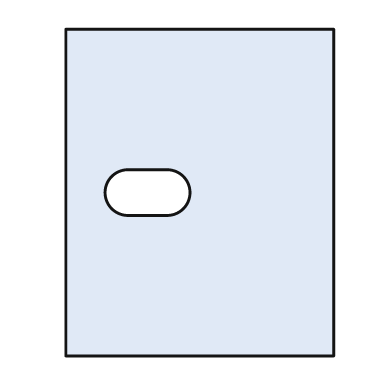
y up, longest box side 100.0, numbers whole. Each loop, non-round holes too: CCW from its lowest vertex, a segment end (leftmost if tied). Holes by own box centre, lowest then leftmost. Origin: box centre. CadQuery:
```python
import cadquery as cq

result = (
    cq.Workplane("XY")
    .moveTo(-41.0, -50.0)
    .lineTo(41.0, -50.0)
    .lineTo(41.0, 50.0)
    .lineTo(-41.0, 50.0)
    .close()
    .moveTo(-22.0, -7.0)
    .lineTo(-10.0, -7.0)
    .threePointArc((-3.0, 0.0), (-10.0, 7.0))
    .lineTo(-22.0, 7.0)
    .threePointArc((-29.0, 0.0), (-22.0, -7.0))
    .close()
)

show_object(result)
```